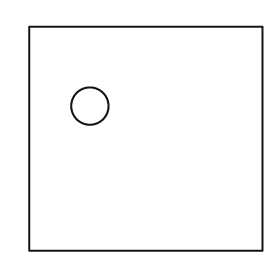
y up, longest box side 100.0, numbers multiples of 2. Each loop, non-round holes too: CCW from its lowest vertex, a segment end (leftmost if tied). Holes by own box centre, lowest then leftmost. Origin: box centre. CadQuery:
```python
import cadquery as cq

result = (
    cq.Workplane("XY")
    .moveTo(-50.0, -48.0)
    .lineTo(50.0, -48.0)
    .lineTo(50.0, 48.0)
    .lineTo(-50.0, 48.0)
    .close()
    .moveTo(-24.0, 14.0)
    .circle(8.0)
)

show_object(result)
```